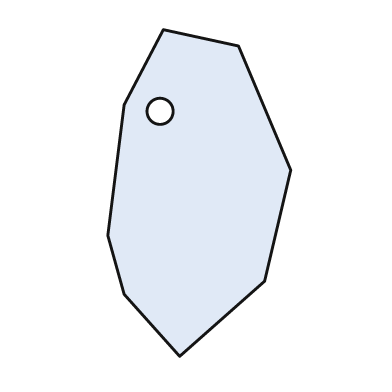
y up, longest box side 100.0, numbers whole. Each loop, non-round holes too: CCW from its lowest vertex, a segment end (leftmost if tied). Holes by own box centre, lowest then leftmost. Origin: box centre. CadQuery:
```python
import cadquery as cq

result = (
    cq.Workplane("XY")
    .moveTo(-6.0, -50.0)
    .lineTo(20.0, -27.0)
    .lineTo(28.0, 7.0)
    .lineTo(12.0, 45.0)
    .lineTo(-11.0, 50.0)
    .lineTo(-23.0, 27.0)
    .lineTo(-28.0, -13.0)
    .lineTo(-23.0, -31.0)
    .close()
    .moveTo(-12.0, 25.0)
    .circle(4.0)
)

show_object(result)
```